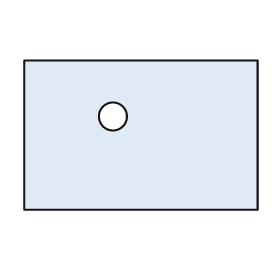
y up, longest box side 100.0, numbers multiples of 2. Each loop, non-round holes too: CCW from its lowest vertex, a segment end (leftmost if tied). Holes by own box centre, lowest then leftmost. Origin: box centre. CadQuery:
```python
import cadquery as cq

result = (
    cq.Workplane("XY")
    .moveTo(-50.0, -32.0)
    .lineTo(50.0, -32.0)
    .lineTo(50.0, 32.0)
    .lineTo(-50.0, 32.0)
    .close()
    .moveTo(-12.0, 8.0)
    .circle(6.0)
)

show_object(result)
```